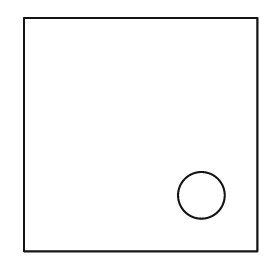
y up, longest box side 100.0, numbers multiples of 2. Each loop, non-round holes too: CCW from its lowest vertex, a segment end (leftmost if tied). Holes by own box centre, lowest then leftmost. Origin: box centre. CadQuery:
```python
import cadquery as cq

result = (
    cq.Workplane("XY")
    .moveTo(-50.0, -50.0)
    .lineTo(50.0, -50.0)
    .lineTo(50.0, 50.0)
    .lineTo(-50.0, 50.0)
    .close()
    .moveTo(26.0, -26.0)
    .circle(10.0)
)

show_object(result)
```